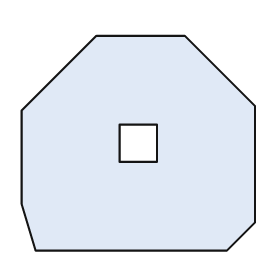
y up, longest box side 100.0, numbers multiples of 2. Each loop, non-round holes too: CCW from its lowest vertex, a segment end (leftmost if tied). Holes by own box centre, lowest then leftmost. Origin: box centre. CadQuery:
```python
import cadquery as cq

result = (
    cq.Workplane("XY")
    .moveTo(-44.0, -46.0)
    .lineTo(38.0, -46.0)
    .lineTo(50.0, -34.0)
    .lineTo(50.0, 16.0)
    .lineTo(20.0, 46.0)
    .lineTo(-18.0, 46.0)
    .lineTo(-50.0, 14.0)
    .lineTo(-50.0, -26.0)
    .close()
    .moveTo(-8.0, -8.0)
    .lineTo(8.0, -8.0)
    .lineTo(8.0, 8.0)
    .lineTo(-8.0, 8.0)
    .close()
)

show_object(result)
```